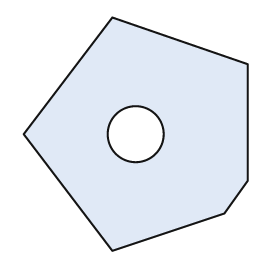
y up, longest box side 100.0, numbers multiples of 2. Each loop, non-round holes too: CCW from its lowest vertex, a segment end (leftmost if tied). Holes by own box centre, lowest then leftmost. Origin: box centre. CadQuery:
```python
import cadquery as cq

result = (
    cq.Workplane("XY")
    .moveTo(-10.0, -50.0)
    .lineTo(38.0, -34.0)
    .lineTo(48.0, -20.0)
    .lineTo(48.0, 30.0)
    .lineTo(-10.0, 50.0)
    .lineTo(-48.0, 0.0)
    .close()
    .moveTo(0.0, 0.0)
    .circle(12.0)
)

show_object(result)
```